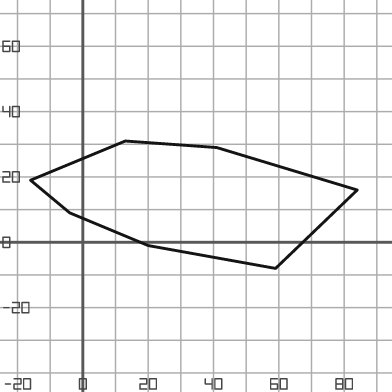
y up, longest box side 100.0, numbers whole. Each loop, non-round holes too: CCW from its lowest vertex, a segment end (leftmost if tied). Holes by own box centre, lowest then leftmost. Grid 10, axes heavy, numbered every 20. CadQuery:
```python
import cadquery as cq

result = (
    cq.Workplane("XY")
    .moveTo(59.0, -8.0)
    .lineTo(84.0, 16.0)
    .lineTo(41.0, 29.0)
    .lineTo(13.0, 31.0)
    .lineTo(-16.0, 19.0)
    .lineTo(-4.0, 9.0)
    .lineTo(20.0, -1.0)
    .close()
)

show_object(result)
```